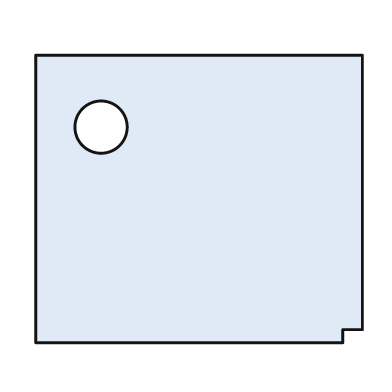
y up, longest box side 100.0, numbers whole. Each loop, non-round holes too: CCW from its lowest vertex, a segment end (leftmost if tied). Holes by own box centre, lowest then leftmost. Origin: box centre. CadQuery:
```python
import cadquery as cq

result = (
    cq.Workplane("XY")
    .moveTo(-50.0, -44.0)
    .lineTo(44.0, -44.0)
    .lineTo(44.0, -40.0)
    .lineTo(50.0, -40.0)
    .lineTo(50.0, 44.0)
    .lineTo(-50.0, 44.0)
    .close()
    .moveTo(-30.0, 22.0)
    .circle(8.0)
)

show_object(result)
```